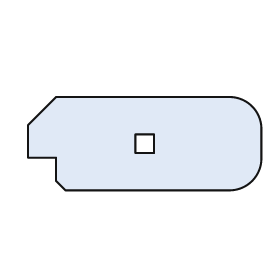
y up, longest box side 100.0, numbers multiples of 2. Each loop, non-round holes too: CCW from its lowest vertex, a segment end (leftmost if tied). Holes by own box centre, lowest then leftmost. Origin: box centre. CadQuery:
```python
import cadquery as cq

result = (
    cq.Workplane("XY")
    .moveTo(-34.0, -20.0)
    .lineTo(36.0, -20.0)
    .threePointArc((46.0, -16.0), (50.0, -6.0))
    .lineTo(50.0, 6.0)
    .threePointArc((46.0, 16.0), (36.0, 20.0))
    .lineTo(-38.0, 20.0)
    .lineTo(-50.0, 8.0)
    .lineTo(-50.0, -6.0)
    .lineTo(-38.0, -6.0)
    .lineTo(-38.0, -16.0)
    .close()
    .moveTo(-4.0, -4.0)
    .lineTo(4.0, -4.0)
    .lineTo(4.0, 4.0)
    .lineTo(-4.0, 4.0)
    .close()
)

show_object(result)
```